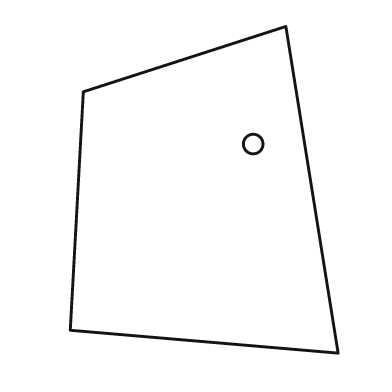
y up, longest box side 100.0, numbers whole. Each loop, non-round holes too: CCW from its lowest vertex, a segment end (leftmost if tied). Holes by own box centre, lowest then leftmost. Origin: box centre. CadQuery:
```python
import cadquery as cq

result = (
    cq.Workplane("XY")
    .moveTo(41.0, -50.0)
    .lineTo(25.0, 50.0)
    .lineTo(-37.0, 30.0)
    .lineTo(-41.0, -43.0)
    .close()
    .moveTo(15.0, 14.0)
    .circle(3.0)
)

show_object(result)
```